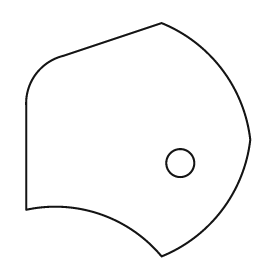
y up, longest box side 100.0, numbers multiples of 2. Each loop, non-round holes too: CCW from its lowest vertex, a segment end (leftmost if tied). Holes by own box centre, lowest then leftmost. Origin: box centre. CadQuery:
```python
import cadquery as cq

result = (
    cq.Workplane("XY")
    .moveTo(10.0, -50.0)
    .threePointArc((36.0, -30.0), (48.0, 0.0))
    .threePointArc((36.0, 30.0), (10.0, 50.0))
    .lineTo(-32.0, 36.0)
    .threePointArc((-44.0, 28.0), (-48.0, 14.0))
    .lineTo(-48.0, -30.0)
    .threePointArc((-16.0, -32.0), (10.0, -50.0))
    .close()
    .moveTo(18.0, -10.0)
    .circle(6.0)
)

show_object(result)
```